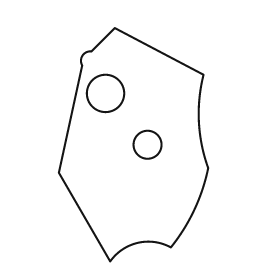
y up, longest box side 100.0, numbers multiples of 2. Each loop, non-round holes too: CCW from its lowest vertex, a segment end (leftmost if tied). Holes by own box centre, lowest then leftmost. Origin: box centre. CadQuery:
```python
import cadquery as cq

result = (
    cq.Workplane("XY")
    .moveTo(-10.0, -50.0)
    .threePointArc((2.0, -42.0), (16.0, -44.0))
    .threePointArc((26.0, -28.0), (32.0, -10.0))
    .threePointArc((28.0, 10.0), (30.0, 30.0))
    .lineTo(-8.0, 50.0)
    .lineTo(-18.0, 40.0)
    .threePointArc((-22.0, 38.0), (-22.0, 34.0))
    .lineTo(-32.0, -12.0)
    .close()
    .moveTo(6.0, 0.0)
    .circle(6.0)
    .moveTo(-12.0, 22.0)
    .circle(8.0)
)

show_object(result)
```